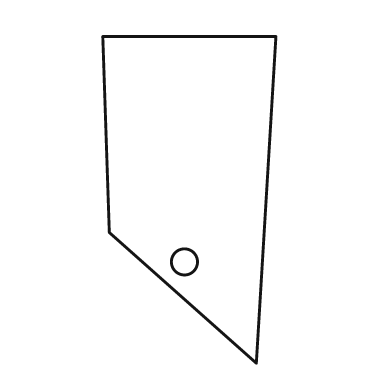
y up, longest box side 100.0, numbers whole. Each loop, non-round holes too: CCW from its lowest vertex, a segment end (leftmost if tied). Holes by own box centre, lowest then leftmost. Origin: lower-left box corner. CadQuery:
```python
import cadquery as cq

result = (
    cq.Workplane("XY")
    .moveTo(47.0, 0.0)
    .lineTo(53.0, 100.0)
    .lineTo(0.0, 100.0)
    .lineTo(2.0, 40.0)
    .close()
    .moveTo(25.0, 31.0)
    .circle(4.0)
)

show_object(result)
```